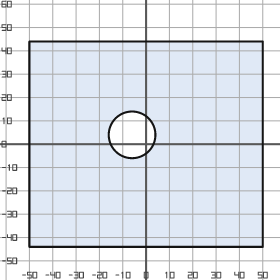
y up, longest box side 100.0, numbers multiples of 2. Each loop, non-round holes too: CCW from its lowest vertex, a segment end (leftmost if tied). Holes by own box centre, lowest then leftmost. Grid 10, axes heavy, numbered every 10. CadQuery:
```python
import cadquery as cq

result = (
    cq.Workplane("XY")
    .moveTo(-50.0, -44.0)
    .lineTo(50.0, -44.0)
    .lineTo(50.0, 44.0)
    .lineTo(-50.0, 44.0)
    .close()
    .moveTo(-6.0, 4.0)
    .circle(10.0)
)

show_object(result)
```